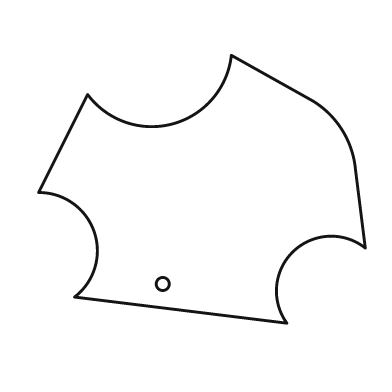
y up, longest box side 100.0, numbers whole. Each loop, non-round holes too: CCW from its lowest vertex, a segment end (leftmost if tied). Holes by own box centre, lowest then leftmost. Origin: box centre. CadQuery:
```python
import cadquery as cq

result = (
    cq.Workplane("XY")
    .moveTo(26.0, -41.0)
    .threePointArc((28.0, -19.0), (50.0, -18.0))
    .lineTo(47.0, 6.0)
    .threePointArc((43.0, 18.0), (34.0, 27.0))
    .lineTo(9.0, 41.0)
    .threePointArc((-9.0, 20.0), (-35.0, 29.0))
    .lineTo(-50.0, -1.0)
    .threePointArc((-33.0, -13.0), (-39.0, -33.0))
    .close()
    .moveTo(-12.0, -29.0)
    .circle(2.0)
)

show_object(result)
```